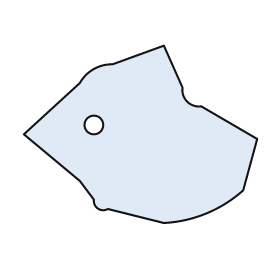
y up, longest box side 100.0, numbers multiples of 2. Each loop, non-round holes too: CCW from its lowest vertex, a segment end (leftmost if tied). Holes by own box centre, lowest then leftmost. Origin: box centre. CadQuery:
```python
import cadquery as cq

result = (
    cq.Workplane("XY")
    .moveTo(10.0, -38.0)
    .threePointArc((28.0, -34.0), (44.0, -24.0))
    .lineTo(50.0, -2.0)
    .lineTo(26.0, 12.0)
    .threePointArc((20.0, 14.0), (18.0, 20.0))
    .lineTo(10.0, 38.0)
    .lineTo(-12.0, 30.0)
    .threePointArc((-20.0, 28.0), (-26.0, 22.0))
    .lineTo(-50.0, 0.0)
    .lineTo(-26.0, -20.0)
    .lineTo(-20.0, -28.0)
    .threePointArc((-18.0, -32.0), (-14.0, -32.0))
    .close()
    .moveTo(-20.0, 4.0)
    .circle(4.0)
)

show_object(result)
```